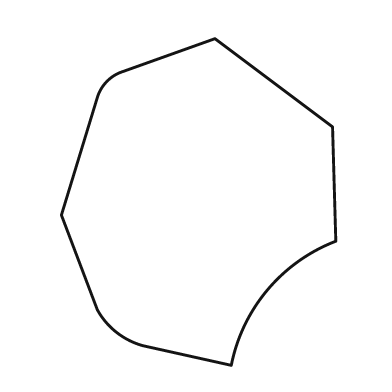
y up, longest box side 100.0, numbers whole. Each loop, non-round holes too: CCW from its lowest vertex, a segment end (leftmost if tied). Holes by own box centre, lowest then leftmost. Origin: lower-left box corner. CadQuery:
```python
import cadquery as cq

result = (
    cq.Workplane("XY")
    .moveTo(52.0, 0.0)
    .threePointArc((63.0, 23.0), (84.0, 38.0))
    .lineTo(83.0, 73.0)
    .lineTo(47.0, 100.0)
    .lineTo(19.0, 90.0)
    .threePointArc((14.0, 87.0), (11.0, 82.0))
    .lineTo(0.0, 46.0)
    .lineTo(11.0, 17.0)
    .threePointArc((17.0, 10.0), (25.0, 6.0))
    .close()
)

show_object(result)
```